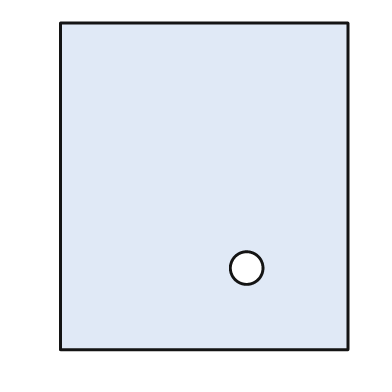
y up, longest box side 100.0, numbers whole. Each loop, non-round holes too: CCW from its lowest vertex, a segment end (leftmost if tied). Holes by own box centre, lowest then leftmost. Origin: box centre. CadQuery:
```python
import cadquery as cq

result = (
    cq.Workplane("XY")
    .moveTo(-44.0, -50.0)
    .lineTo(44.0, -50.0)
    .lineTo(44.0, 50.0)
    .lineTo(-44.0, 50.0)
    .close()
    .moveTo(13.0, -25.0)
    .circle(5.0)
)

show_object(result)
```